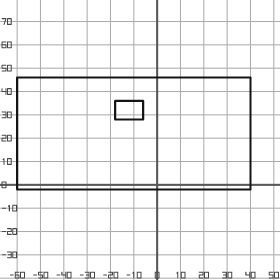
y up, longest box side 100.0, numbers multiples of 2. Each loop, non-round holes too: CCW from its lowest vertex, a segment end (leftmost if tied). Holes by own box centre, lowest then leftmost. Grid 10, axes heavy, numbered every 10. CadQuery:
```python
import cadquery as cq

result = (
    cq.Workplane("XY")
    .moveTo(-60.0, -2.0)
    .lineTo(40.0, -2.0)
    .lineTo(40.0, 46.0)
    .lineTo(-60.0, 46.0)
    .close()
    .moveTo(-18.0, 28.0)
    .lineTo(-6.0, 28.0)
    .lineTo(-6.0, 36.0)
    .lineTo(-18.0, 36.0)
    .close()
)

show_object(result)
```